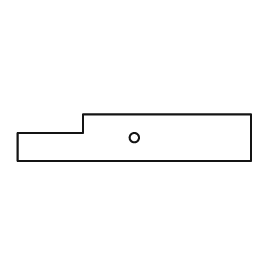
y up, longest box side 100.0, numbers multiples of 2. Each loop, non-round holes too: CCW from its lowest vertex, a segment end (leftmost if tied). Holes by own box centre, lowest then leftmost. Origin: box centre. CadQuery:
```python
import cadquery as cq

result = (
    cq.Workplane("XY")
    .moveTo(-50.0, -10.0)
    .lineTo(50.0, -10.0)
    .lineTo(50.0, 10.0)
    .lineTo(-22.0, 10.0)
    .lineTo(-22.0, 2.0)
    .lineTo(-50.0, 2.0)
    .close()
    .moveTo(0.0, 0.0)
    .circle(2.0)
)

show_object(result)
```